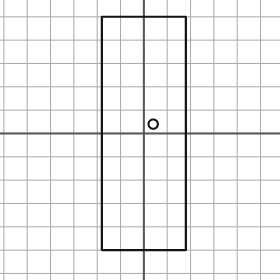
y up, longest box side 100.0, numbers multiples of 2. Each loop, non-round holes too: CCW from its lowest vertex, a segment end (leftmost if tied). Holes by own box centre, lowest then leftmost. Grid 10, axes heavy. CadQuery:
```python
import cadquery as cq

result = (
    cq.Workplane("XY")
    .moveTo(-18.0, -50.0)
    .lineTo(18.0, -50.0)
    .lineTo(18.0, 50.0)
    .lineTo(-18.0, 50.0)
    .close()
    .moveTo(4.0, 4.0)
    .circle(2.0)
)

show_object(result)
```